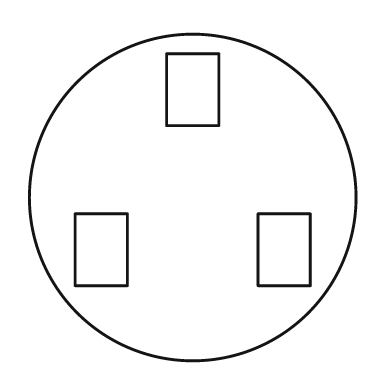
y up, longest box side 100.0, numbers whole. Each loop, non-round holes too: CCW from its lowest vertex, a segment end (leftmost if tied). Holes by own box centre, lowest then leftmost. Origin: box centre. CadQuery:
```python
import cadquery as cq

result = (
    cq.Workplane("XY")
    .moveTo(0.0, 0.0)
    .circle(50.0)
    .moveTo(-36.0, -27.0)
    .lineTo(-20.0, -27.0)
    .lineTo(-20.0, -5.0)
    .lineTo(-36.0, -5.0)
    .close()
    .moveTo(20.0, -27.0)
    .lineTo(36.0, -27.0)
    .lineTo(36.0, -5.0)
    .lineTo(20.0, -5.0)
    .close()
    .moveTo(-8.0, 22.0)
    .lineTo(8.0, 22.0)
    .lineTo(8.0, 44.0)
    .lineTo(-8.0, 44.0)
    .close()
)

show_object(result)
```